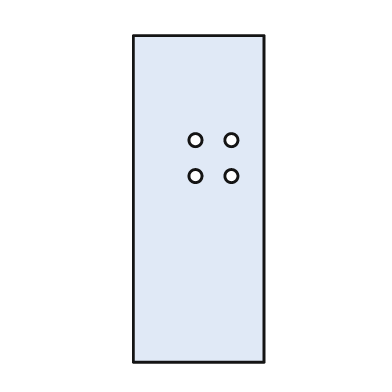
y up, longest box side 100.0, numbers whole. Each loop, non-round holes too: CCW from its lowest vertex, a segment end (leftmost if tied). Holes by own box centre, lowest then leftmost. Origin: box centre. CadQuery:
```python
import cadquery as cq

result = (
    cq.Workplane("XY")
    .moveTo(-20.0, -50.0)
    .lineTo(20.0, -50.0)
    .lineTo(20.0, 50.0)
    .lineTo(-20.0, 50.0)
    .close()
    .moveTo(-1.0, 7.0)
    .circle(2.0)
    .moveTo(10.0, 7.0)
    .circle(2.0)
    .moveTo(-1.0, 18.0)
    .circle(2.0)
    .moveTo(10.0, 18.0)
    .circle(2.0)
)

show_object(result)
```